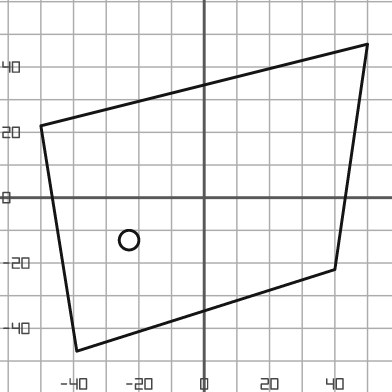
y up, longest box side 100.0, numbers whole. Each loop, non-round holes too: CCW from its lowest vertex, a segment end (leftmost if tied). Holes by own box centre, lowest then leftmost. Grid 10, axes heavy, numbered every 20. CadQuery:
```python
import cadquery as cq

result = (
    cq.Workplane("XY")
    .moveTo(-39.0, -47.0)
    .lineTo(40.0, -22.0)
    .lineTo(50.0, 47.0)
    .lineTo(-50.0, 22.0)
    .close()
    .moveTo(-23.0, -13.0)
    .circle(3.0)
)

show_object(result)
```